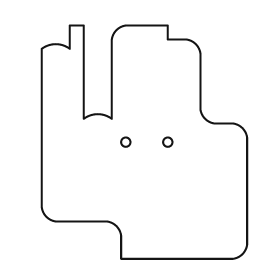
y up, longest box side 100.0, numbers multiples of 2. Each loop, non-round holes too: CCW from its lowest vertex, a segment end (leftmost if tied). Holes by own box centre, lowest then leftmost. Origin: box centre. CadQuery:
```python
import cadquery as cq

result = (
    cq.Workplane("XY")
    .moveTo(-10.0, -50.0)
    .lineTo(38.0, -50.0)
    .threePointArc((42.0, -48.0), (44.0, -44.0))
    .lineTo(44.0, 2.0)
    .threePointArc((42.0, 6.0), (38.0, 8.0))
    .lineTo(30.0, 8.0)
    .threePointArc((26.0, 10.0), (24.0, 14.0))
    .lineTo(24.0, 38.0)
    .threePointArc((22.0, 42.0), (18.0, 44.0))
    .lineTo(10.0, 44.0)
    .lineTo(10.0, 50.0)
    .lineTo(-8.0, 50.0)
    .threePointArc((-12.0, 48.0), (-14.0, 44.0))
    .lineTo(-14.0, 10.0)
    .threePointArc((-20.0, 12.0), (-26.0, 10.0))
    .lineTo(-26.0, 50.0)
    .lineTo(-32.0, 50.0)
    .lineTo(-32.0, 40.0)
    .threePointArc((-38.0, 42.0), (-44.0, 40.0))
    .lineTo(-44.0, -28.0)
    .threePointArc((-42.0, -32.0), (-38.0, -34.0))
    .lineTo(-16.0, -34.0)
    .threePointArc((-12.0, -36.0), (-10.0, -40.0))
    .close()
    .moveTo(-8.0, 0.0)
    .circle(2.0)
    .moveTo(10.0, 0.0)
    .circle(2.0)
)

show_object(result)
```